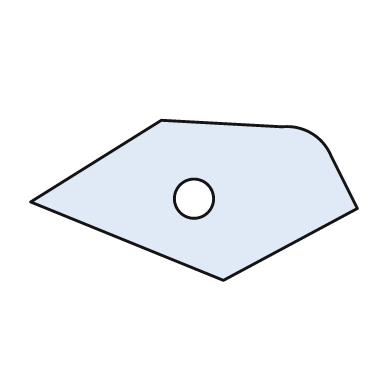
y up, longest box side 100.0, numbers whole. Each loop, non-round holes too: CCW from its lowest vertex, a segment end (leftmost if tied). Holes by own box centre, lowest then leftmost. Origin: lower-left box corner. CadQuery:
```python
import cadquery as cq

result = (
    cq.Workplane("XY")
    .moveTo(59.0, 0.0)
    .lineTo(100.0, 22.0)
    .lineTo(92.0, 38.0)
    .threePointArc((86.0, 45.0), (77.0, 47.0))
    .lineTo(40.0, 49.0)
    .lineTo(0.0, 24.0)
    .close()
    .moveTo(50.0, 25.0)
    .circle(6.0)
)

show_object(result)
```